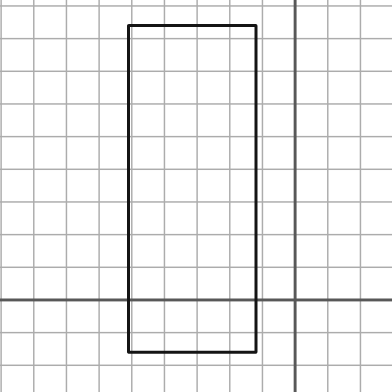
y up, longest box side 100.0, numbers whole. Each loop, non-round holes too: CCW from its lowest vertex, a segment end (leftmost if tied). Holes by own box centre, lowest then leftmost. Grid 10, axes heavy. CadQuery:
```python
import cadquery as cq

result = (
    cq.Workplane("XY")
    .moveTo(-51.0, -16.0)
    .lineTo(-12.0, -16.0)
    .lineTo(-12.0, 84.0)
    .lineTo(-51.0, 84.0)
    .close()
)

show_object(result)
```